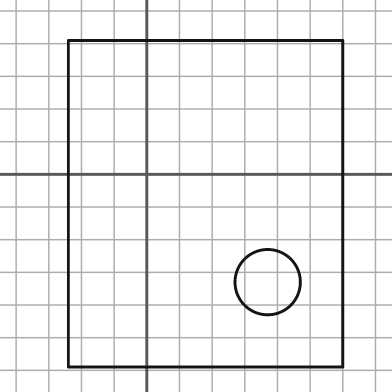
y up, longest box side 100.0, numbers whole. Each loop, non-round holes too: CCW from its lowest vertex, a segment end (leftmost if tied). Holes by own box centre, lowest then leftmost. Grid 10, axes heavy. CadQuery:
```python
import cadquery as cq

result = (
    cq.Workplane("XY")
    .moveTo(-24.0, -59.0)
    .lineTo(60.0, -59.0)
    .lineTo(60.0, 41.0)
    .lineTo(-24.0, 41.0)
    .close()
    .moveTo(37.0, -33.0)
    .circle(10.0)
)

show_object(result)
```